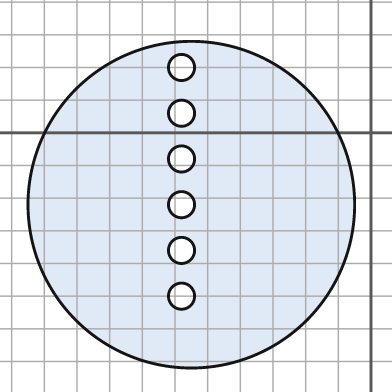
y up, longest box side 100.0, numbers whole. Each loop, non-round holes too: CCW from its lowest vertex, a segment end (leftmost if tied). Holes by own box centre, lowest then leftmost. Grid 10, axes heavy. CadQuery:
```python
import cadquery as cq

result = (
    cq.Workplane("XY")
    .moveTo(-55.0, -22.0)
    .circle(50.0)
    .moveTo(-58.0, -50.0)
    .circle(4.0)
    .moveTo(-58.0, -36.0)
    .circle(4.0)
    .moveTo(-58.0, -22.0)
    .circle(4.0)
    .moveTo(-58.0, -8.0)
    .circle(4.0)
    .moveTo(-58.0, 6.0)
    .circle(4.0)
    .moveTo(-58.0, 20.0)
    .circle(4.0)
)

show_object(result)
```